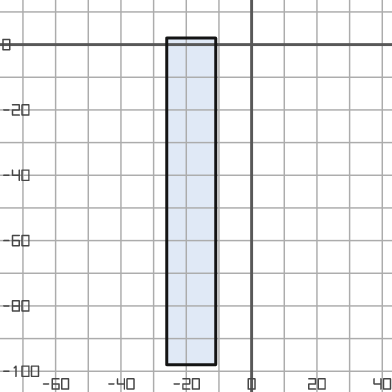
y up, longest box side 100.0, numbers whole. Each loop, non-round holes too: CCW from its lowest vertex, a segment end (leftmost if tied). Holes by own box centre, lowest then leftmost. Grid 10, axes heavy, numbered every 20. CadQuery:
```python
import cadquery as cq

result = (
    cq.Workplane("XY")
    .moveTo(-26.0, -98.0)
    .lineTo(-11.0, -98.0)
    .lineTo(-11.0, 2.0)
    .lineTo(-26.0, 2.0)
    .close()
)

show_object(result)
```